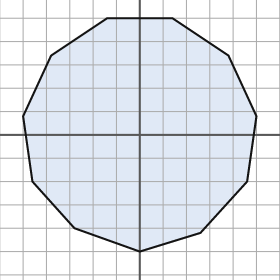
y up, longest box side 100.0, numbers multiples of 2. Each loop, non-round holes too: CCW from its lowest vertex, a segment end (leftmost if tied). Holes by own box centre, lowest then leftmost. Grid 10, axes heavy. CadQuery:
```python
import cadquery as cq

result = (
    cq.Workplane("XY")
    .moveTo(0.0, -50.0)
    .lineTo(26.0, -42.0)
    .lineTo(46.0, -20.0)
    .lineTo(50.0, 8.0)
    .lineTo(38.0, 34.0)
    .lineTo(14.0, 50.0)
    .lineTo(-14.0, 50.0)
    .lineTo(-38.0, 34.0)
    .lineTo(-50.0, 8.0)
    .lineTo(-46.0, -20.0)
    .lineTo(-28.0, -40.0)
    .close()
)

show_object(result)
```